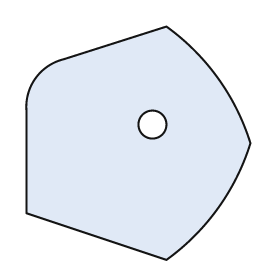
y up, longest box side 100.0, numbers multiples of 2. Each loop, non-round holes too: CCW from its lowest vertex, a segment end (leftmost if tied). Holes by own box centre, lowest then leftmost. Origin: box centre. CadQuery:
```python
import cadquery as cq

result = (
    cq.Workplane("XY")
    .moveTo(12.0, -50.0)
    .threePointArc((34.0, -28.0), (48.0, 0.0))
    .threePointArc((34.0, 28.0), (12.0, 50.0))
    .lineTo(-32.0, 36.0)
    .threePointArc((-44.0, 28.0), (-48.0, 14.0))
    .lineTo(-48.0, -30.0)
    .close()
    .moveTo(6.0, 8.0)
    .circle(6.0)
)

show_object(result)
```